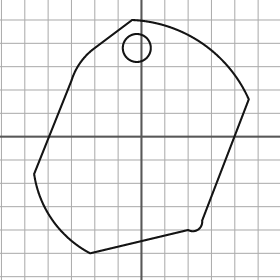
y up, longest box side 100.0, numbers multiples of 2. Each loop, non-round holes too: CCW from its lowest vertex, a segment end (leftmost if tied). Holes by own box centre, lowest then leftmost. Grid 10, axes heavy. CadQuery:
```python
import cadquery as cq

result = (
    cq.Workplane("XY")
    .moveTo(-22.0, -50.0)
    .lineTo(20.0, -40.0)
    .threePointArc((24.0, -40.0), (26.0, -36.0))
    .lineTo(46.0, 16.0)
    .threePointArc((26.0, 40.0), (-4.0, 50.0))
    .lineTo(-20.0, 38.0)
    .threePointArc((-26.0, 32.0), (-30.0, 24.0))
    .lineTo(-46.0, -16.0)
    .threePointArc((-38.0, -36.0), (-22.0, -50.0))
    .close()
    .moveTo(-2.0, 38.0)
    .circle(6.0)
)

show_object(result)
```